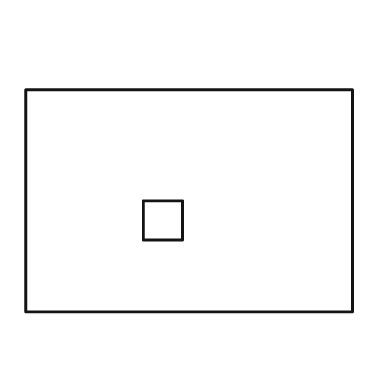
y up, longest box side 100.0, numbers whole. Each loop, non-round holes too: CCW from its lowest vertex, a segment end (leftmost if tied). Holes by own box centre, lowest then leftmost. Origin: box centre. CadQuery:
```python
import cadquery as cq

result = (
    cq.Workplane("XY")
    .moveTo(-50.0, -34.0)
    .lineTo(50.0, -34.0)
    .lineTo(50.0, 34.0)
    .lineTo(-50.0, 34.0)
    .close()
    .moveTo(-14.0, -12.0)
    .lineTo(-2.0, -12.0)
    .lineTo(-2.0, 0.0)
    .lineTo(-14.0, 0.0)
    .close()
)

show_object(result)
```